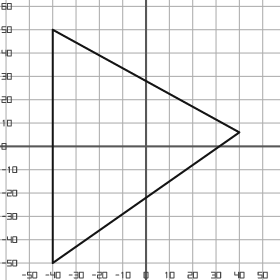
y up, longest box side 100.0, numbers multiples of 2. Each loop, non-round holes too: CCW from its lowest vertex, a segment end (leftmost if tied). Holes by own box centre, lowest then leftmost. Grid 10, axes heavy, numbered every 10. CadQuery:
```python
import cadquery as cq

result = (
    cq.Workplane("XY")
    .moveTo(-40.0, -50.0)
    .lineTo(40.0, 6.0)
    .lineTo(-40.0, 50.0)
    .close()
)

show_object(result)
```